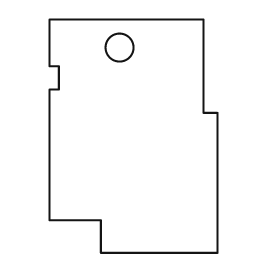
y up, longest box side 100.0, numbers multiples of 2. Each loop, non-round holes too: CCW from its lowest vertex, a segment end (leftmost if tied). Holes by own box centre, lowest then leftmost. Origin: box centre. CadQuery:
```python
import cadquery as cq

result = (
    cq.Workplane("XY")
    .moveTo(-14.0, -50.0)
    .lineTo(36.0, -50.0)
    .lineTo(36.0, 10.0)
    .lineTo(30.0, 10.0)
    .lineTo(30.0, 50.0)
    .lineTo(-36.0, 50.0)
    .lineTo(-36.0, 30.0)
    .lineTo(-32.0, 30.0)
    .lineTo(-32.0, 20.0)
    .lineTo(-36.0, 20.0)
    .lineTo(-36.0, -36.0)
    .lineTo(-14.0, -36.0)
    .close()
    .moveTo(-6.0, 38.0)
    .circle(6.0)
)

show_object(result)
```